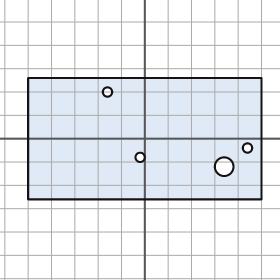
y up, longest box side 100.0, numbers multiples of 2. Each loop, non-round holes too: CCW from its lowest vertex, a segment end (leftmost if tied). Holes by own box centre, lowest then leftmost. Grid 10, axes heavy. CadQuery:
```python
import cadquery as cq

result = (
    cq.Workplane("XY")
    .moveTo(-50.0, -26.0)
    .lineTo(50.0, -26.0)
    .lineTo(50.0, 26.0)
    .lineTo(-50.0, 26.0)
    .close()
    .moveTo(34.0, -12.0)
    .circle(4.0)
    .moveTo(-2.0, -8.0)
    .circle(2.0)
    .moveTo(44.0, -4.0)
    .circle(2.0)
    .moveTo(-16.0, 20.0)
    .circle(2.0)
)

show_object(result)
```